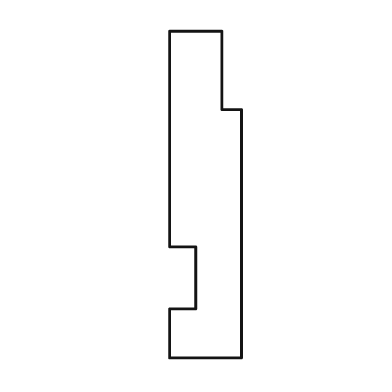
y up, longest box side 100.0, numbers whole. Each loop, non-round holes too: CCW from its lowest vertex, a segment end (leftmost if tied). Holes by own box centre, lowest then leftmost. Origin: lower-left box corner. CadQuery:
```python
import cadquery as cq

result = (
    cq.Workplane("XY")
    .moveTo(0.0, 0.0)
    .lineTo(22.0, 0.0)
    .lineTo(22.0, 76.0)
    .lineTo(16.0, 76.0)
    .lineTo(16.0, 100.0)
    .lineTo(0.0, 100.0)
    .lineTo(0.0, 34.0)
    .lineTo(8.0, 34.0)
    .lineTo(8.0, 15.0)
    .lineTo(0.0, 15.0)
    .close()
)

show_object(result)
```